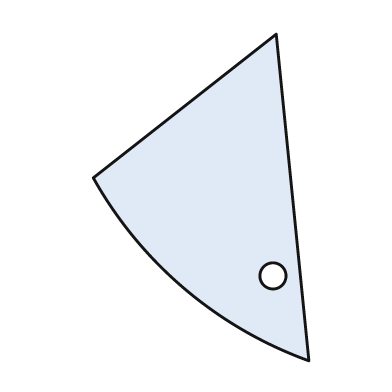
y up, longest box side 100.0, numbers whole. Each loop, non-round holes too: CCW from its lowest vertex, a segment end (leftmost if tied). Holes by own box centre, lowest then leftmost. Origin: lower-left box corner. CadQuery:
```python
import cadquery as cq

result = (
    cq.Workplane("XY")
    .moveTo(66.0, 0.0)
    .lineTo(56.0, 100.0)
    .lineTo(0.0, 56.0)
    .threePointArc((28.0, 22.0), (66.0, 0.0))
    .close()
    .moveTo(55.0, 26.0)
    .circle(4.0)
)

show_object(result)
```